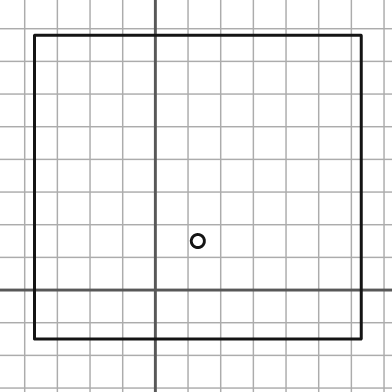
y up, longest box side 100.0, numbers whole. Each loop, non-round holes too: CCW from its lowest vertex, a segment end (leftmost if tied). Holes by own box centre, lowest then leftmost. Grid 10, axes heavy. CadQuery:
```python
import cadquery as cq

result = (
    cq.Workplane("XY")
    .moveTo(-37.0, -15.0)
    .lineTo(63.0, -15.0)
    .lineTo(63.0, 78.0)
    .lineTo(-37.0, 78.0)
    .close()
    .moveTo(13.0, 15.0)
    .circle(2.0)
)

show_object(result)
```